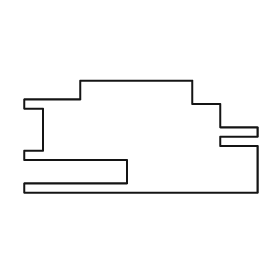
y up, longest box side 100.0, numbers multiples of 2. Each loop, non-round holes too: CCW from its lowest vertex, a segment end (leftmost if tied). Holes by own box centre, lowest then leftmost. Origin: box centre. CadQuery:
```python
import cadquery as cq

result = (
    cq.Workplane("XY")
    .moveTo(-50.0, -24.0)
    .lineTo(50.0, -24.0)
    .lineTo(50.0, -4.0)
    .lineTo(34.0, -4.0)
    .lineTo(34.0, 0.0)
    .lineTo(50.0, 0.0)
    .lineTo(50.0, 4.0)
    .lineTo(34.0, 4.0)
    .lineTo(34.0, 14.0)
    .lineTo(22.0, 14.0)
    .lineTo(22.0, 24.0)
    .lineTo(-26.0, 24.0)
    .lineTo(-26.0, 16.0)
    .lineTo(-50.0, 16.0)
    .lineTo(-50.0, 12.0)
    .lineTo(-42.0, 12.0)
    .lineTo(-42.0, -6.0)
    .lineTo(-50.0, -6.0)
    .lineTo(-50.0, -10.0)
    .lineTo(-6.0, -10.0)
    .lineTo(-6.0, -20.0)
    .lineTo(-50.0, -20.0)
    .close()
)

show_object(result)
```